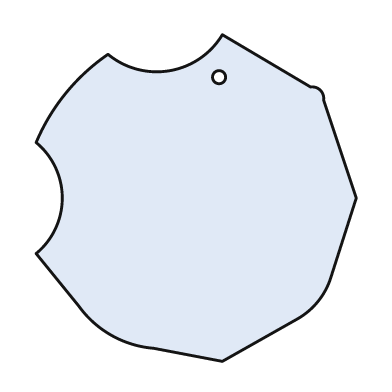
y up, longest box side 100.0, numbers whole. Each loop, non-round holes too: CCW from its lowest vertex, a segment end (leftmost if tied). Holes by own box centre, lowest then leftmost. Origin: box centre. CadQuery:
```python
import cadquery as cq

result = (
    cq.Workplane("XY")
    .moveTo(8.0, -50.0)
    .lineTo(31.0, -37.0)
    .threePointArc((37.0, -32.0), (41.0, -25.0))
    .lineTo(49.0, 0.0)
    .lineTo(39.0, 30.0)
    .threePointArc((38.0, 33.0), (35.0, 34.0))
    .lineTo(8.0, 50.0)
    .threePointArc((-8.0, 39.0), (-27.0, 44.0))
    .threePointArc((-40.0, 32.0), (-49.0, 17.0))
    .threePointArc((-41.0, 0.0), (-49.0, -17.0))
    .lineTo(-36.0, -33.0)
    .threePointArc((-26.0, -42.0), (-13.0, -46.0))
    .close()
    .moveTo(7.0, 37.0)
    .circle(2.0)
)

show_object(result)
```